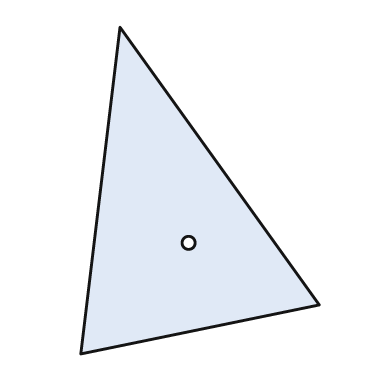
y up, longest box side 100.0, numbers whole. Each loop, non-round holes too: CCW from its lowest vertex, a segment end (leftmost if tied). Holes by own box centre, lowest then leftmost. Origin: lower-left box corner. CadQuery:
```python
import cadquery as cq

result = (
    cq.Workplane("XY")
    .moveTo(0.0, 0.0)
    .lineTo(73.0, 15.0)
    .lineTo(12.0, 100.0)
    .close()
    .moveTo(33.0, 34.0)
    .circle(2.0)
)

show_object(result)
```